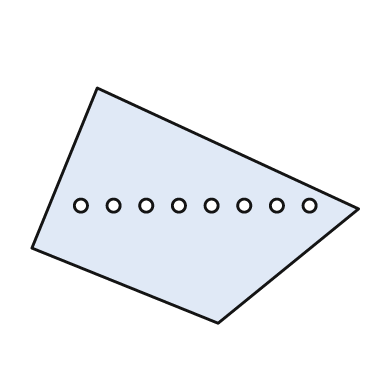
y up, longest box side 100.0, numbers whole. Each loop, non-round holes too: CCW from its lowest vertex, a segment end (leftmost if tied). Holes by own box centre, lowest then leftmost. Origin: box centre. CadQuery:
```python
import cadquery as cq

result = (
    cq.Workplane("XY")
    .moveTo(7.0, -36.0)
    .lineTo(50.0, -1.0)
    .lineTo(-30.0, 36.0)
    .lineTo(-50.0, -13.0)
    .close()
    .moveTo(-35.0, 0.0)
    .circle(2.0)
    .moveTo(-25.0, 0.0)
    .circle(2.0)
    .moveTo(-15.0, 0.0)
    .circle(2.0)
    .moveTo(-5.0, 0.0)
    .circle(2.0)
    .moveTo(5.0, 0.0)
    .circle(2.0)
    .moveTo(15.0, 0.0)
    .circle(2.0)
    .moveTo(25.0, 0.0)
    .circle(2.0)
    .moveTo(35.0, 0.0)
    .circle(2.0)
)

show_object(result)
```